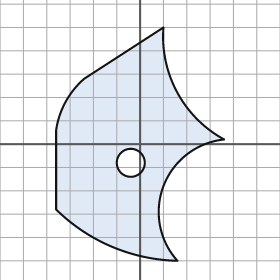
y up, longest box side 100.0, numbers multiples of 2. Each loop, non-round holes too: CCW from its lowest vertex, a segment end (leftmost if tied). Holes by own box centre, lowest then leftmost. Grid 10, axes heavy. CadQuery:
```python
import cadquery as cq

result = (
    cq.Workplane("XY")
    .moveTo(16.0, -50.0)
    .threePointArc((10.0, -18.0), (36.0, 2.0))
    .threePointArc((16.0, 22.0), (10.0, 50.0))
    .lineTo(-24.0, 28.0)
    .threePointArc((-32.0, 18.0), (-36.0, 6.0))
    .lineTo(-36.0, -28.0)
    .threePointArc((-12.0, -44.0), (16.0, -50.0))
    .close()
    .moveTo(-4.0, -8.0)
    .circle(6.0)
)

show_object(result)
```